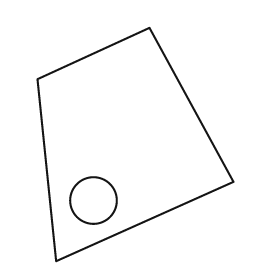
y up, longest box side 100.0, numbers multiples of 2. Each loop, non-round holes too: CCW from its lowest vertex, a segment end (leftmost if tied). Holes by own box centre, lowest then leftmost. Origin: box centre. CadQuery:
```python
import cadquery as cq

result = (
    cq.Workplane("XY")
    .moveTo(-34.0, -50.0)
    .lineTo(42.0, -16.0)
    .lineTo(6.0, 50.0)
    .lineTo(-42.0, 28.0)
    .close()
    .moveTo(-18.0, -24.0)
    .circle(10.0)
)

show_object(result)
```